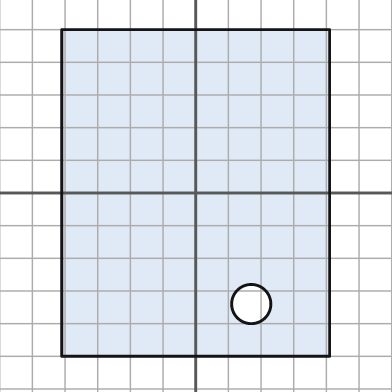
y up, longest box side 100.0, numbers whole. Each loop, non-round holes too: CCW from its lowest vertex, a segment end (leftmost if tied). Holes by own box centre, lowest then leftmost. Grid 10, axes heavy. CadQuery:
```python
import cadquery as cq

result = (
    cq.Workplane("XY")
    .moveTo(-41.0, -50.0)
    .lineTo(41.0, -50.0)
    .lineTo(41.0, 50.0)
    .lineTo(-41.0, 50.0)
    .close()
    .moveTo(17.0, -34.0)
    .circle(6.0)
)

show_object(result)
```